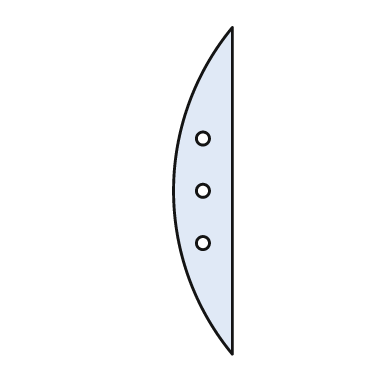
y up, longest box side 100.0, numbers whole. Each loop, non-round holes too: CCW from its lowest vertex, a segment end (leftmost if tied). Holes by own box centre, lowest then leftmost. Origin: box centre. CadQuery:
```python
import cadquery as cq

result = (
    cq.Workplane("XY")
    .moveTo(9.0, -50.0)
    .lineTo(9.0, 50.0)
    .threePointArc((-9.0, 0.0), (9.0, -50.0))
    .close()
    .moveTo(0.0, -16.0)
    .circle(2.0)
    .moveTo(0.0, 0.0)
    .circle(2.0)
    .moveTo(0.0, 16.0)
    .circle(2.0)
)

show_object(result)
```